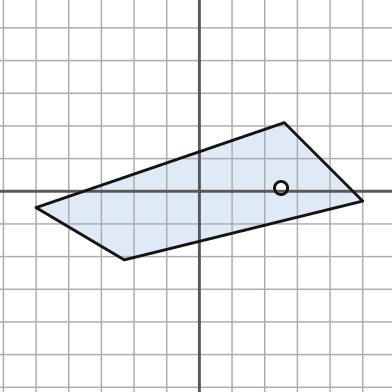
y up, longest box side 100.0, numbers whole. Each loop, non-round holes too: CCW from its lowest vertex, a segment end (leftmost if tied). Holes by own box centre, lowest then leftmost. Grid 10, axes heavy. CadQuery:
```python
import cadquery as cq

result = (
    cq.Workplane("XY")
    .moveTo(-23.0, -21.0)
    .lineTo(50.0, -3.0)
    .lineTo(26.0, 21.0)
    .lineTo(-50.0, -5.0)
    .close()
    .moveTo(25.0, 1.0)
    .circle(2.0)
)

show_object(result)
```